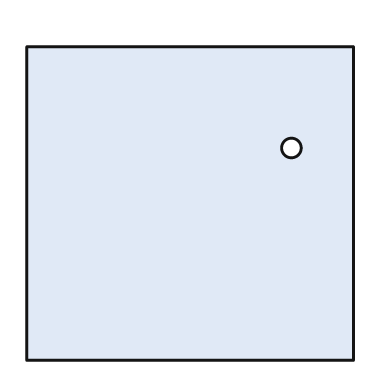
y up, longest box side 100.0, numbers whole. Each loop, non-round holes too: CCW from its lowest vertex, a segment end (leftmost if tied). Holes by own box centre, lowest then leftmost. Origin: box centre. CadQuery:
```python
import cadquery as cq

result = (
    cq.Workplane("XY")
    .moveTo(-50.0, -48.0)
    .lineTo(50.0, -48.0)
    .lineTo(50.0, 48.0)
    .lineTo(-50.0, 48.0)
    .close()
    .moveTo(31.0, 17.0)
    .circle(3.0)
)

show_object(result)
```